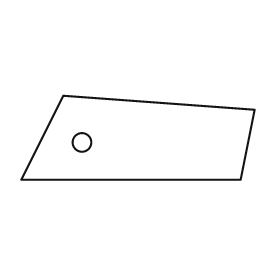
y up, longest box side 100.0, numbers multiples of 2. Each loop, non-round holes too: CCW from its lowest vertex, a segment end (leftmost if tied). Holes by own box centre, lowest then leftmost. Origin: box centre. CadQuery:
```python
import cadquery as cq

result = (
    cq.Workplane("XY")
    .moveTo(-50.0, -18.0)
    .lineTo(44.0, -18.0)
    .lineTo(50.0, 12.0)
    .lineTo(-32.0, 18.0)
    .close()
    .moveTo(-24.0, -2.0)
    .circle(4.0)
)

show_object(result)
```